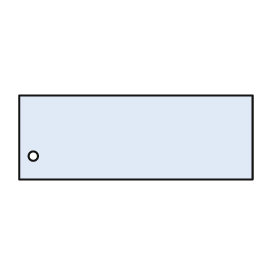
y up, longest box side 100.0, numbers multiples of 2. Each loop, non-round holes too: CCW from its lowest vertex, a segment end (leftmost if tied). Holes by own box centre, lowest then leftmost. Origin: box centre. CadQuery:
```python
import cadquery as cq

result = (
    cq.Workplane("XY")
    .moveTo(-50.0, -18.0)
    .lineTo(50.0, -18.0)
    .lineTo(50.0, 18.0)
    .lineTo(-50.0, 18.0)
    .close()
    .moveTo(-44.0, -8.0)
    .circle(2.0)
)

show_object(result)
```